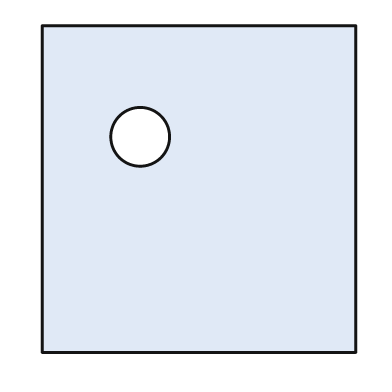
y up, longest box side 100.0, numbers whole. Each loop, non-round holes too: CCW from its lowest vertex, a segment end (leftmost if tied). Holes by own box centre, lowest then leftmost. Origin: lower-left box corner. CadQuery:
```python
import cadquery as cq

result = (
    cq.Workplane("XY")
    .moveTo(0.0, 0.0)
    .lineTo(96.0, 0.0)
    .lineTo(96.0, 100.0)
    .lineTo(0.0, 100.0)
    .close()
    .moveTo(30.0, 66.0)
    .circle(9.0)
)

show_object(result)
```